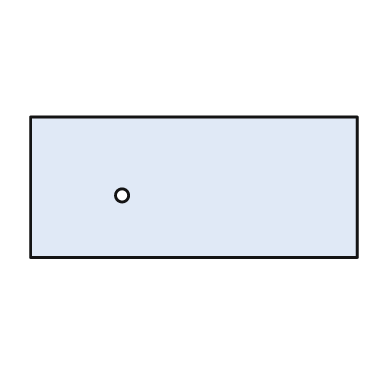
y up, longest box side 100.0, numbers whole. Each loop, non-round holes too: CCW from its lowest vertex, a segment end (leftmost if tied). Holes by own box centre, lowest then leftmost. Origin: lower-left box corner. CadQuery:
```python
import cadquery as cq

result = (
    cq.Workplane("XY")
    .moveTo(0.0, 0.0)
    .lineTo(100.0, 0.0)
    .lineTo(100.0, 43.0)
    .lineTo(0.0, 43.0)
    .close()
    .moveTo(28.0, 19.0)
    .circle(2.0)
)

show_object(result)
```